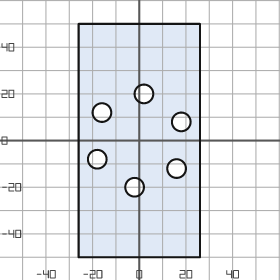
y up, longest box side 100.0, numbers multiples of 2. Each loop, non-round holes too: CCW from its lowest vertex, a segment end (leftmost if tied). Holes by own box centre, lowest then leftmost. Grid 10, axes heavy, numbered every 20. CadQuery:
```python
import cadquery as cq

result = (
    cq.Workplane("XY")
    .moveTo(-26.0, -50.0)
    .lineTo(26.0, -50.0)
    .lineTo(26.0, 50.0)
    .lineTo(-26.0, 50.0)
    .close()
    .moveTo(-2.0, -20.0)
    .circle(4.0)
    .moveTo(16.0, -12.0)
    .circle(4.0)
    .moveTo(-18.0, -8.0)
    .circle(4.0)
    .moveTo(18.0, 8.0)
    .circle(4.0)
    .moveTo(-16.0, 12.0)
    .circle(4.0)
    .moveTo(2.0, 20.0)
    .circle(4.0)
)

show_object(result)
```